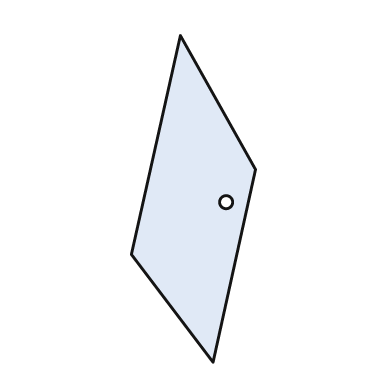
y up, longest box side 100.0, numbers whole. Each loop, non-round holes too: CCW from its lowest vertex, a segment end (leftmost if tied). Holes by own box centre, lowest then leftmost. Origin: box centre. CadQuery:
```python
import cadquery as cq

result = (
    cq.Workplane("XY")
    .moveTo(6.0, -50.0)
    .lineTo(19.0, 9.0)
    .lineTo(-4.0, 50.0)
    .lineTo(-19.0, -17.0)
    .close()
    .moveTo(10.0, -1.0)
    .circle(2.0)
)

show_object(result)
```